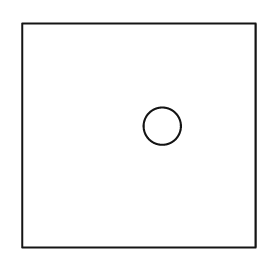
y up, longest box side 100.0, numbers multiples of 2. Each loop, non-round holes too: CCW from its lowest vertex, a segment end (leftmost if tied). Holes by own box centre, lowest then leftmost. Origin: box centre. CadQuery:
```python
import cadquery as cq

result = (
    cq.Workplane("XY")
    .moveTo(-50.0, -48.0)
    .lineTo(50.0, -48.0)
    .lineTo(50.0, 48.0)
    .lineTo(-50.0, 48.0)
    .close()
    .moveTo(10.0, 4.0)
    .circle(8.0)
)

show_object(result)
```